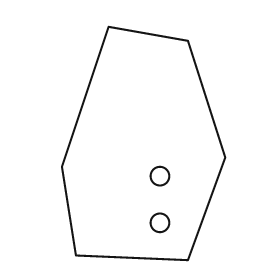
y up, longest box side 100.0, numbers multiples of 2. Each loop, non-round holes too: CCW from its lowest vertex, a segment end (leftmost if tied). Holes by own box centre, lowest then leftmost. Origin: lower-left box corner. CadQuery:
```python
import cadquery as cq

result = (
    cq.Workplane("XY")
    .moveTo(54.0, 0.0)
    .lineTo(70.0, 44.0)
    .lineTo(54.0, 94.0)
    .lineTo(20.0, 100.0)
    .lineTo(0.0, 40.0)
    .lineTo(6.0, 2.0)
    .close()
    .moveTo(42.0, 16.0)
    .circle(4.0)
    .moveTo(42.0, 36.0)
    .circle(4.0)
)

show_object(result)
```